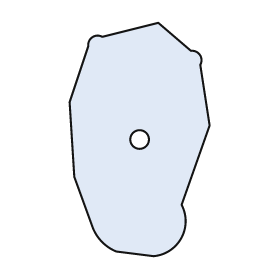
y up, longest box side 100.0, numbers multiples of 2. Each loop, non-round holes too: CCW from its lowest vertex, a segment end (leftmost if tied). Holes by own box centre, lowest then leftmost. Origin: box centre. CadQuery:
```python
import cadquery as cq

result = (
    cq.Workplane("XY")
    .moveTo(6.0, -50.0)
    .threePointArc((18.0, -42.0), (18.0, -28.0))
    .lineTo(30.0, 6.0)
    .lineTo(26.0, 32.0)
    .threePointArc((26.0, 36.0), (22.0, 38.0))
    .lineTo(8.0, 50.0)
    .lineTo(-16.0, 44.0)
    .threePointArc((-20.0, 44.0), (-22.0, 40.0))
    .lineTo(-30.0, 16.0)
    .lineTo(-28.0, -16.0)
    .lineTo(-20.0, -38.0)
    .threePointArc((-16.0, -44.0), (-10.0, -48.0))
    .close()
    .moveTo(0.0, 0.0)
    .circle(4.0)
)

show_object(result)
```